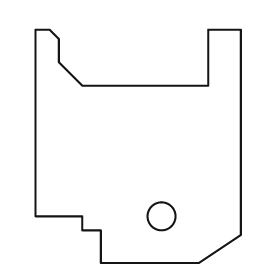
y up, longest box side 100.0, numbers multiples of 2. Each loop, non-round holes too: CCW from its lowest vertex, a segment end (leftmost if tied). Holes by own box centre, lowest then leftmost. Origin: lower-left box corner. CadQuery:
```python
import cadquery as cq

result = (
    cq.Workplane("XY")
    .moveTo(28.0, 0.0)
    .lineTo(70.0, 0.0)
    .lineTo(88.0, 12.0)
    .lineTo(88.0, 100.0)
    .lineTo(74.0, 100.0)
    .lineTo(74.0, 76.0)
    .lineTo(20.0, 76.0)
    .lineTo(10.0, 86.0)
    .lineTo(10.0, 96.0)
    .lineTo(6.0, 100.0)
    .lineTo(0.0, 100.0)
    .lineTo(0.0, 20.0)
    .lineTo(20.0, 20.0)
    .lineTo(20.0, 14.0)
    .lineTo(28.0, 14.0)
    .close()
    .moveTo(54.0, 20.0)
    .circle(6.0)
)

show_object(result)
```